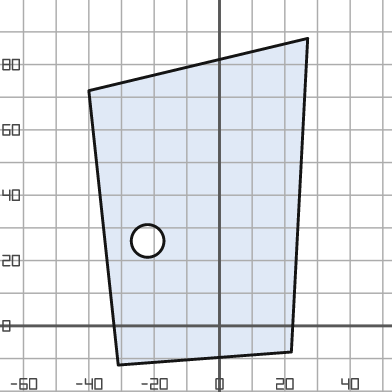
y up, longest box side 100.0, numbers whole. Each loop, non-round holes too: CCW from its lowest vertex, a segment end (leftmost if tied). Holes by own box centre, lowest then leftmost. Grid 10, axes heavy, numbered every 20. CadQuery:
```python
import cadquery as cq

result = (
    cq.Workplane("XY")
    .moveTo(-31.0, -12.0)
    .lineTo(22.0, -8.0)
    .lineTo(27.0, 88.0)
    .lineTo(-40.0, 72.0)
    .close()
    .moveTo(-22.0, 26.0)
    .circle(5.0)
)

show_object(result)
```